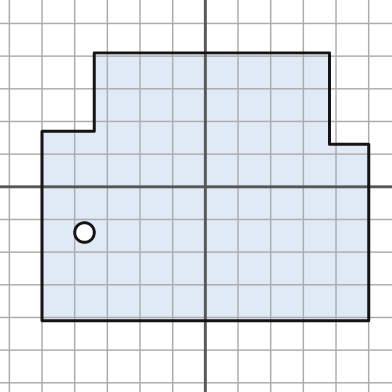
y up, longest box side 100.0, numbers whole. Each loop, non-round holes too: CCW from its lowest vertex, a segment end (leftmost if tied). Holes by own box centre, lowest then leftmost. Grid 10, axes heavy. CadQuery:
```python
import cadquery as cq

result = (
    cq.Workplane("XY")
    .moveTo(-50.0, -41.0)
    .lineTo(50.0, -41.0)
    .lineTo(50.0, 13.0)
    .lineTo(38.0, 13.0)
    .lineTo(38.0, 41.0)
    .lineTo(-34.0, 41.0)
    .lineTo(-34.0, 17.0)
    .lineTo(-50.0, 17.0)
    .close()
    .moveTo(-37.0, -14.0)
    .circle(3.0)
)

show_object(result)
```